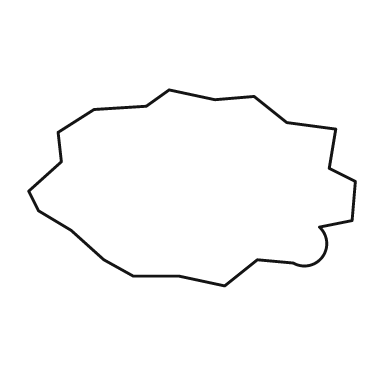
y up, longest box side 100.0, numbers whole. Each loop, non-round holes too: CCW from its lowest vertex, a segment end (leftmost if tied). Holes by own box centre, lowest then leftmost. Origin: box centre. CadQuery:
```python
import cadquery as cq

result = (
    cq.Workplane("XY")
    .moveTo(10.0, -30.0)
    .lineTo(20.0, -22.0)
    .lineTo(31.0, -23.0)
    .threePointArc((40.0, -21.0), (39.0, -12.0))
    .lineTo(49.0, -10.0)
    .lineTo(50.0, 2.0)
    .lineTo(42.0, 6.0)
    .lineTo(44.0, 18.0)
    .lineTo(29.0, 20.0)
    .lineTo(19.0, 28.0)
    .lineTo(7.0, 27.0)
    .lineTo(-7.0, 30.0)
    .lineTo(-14.0, 25.0)
    .lineTo(-30.0, 24.0)
    .lineTo(-41.0, 17.0)
    .lineTo(-40.0, 8.0)
    .lineTo(-50.0, -1.0)
    .lineTo(-47.0, -7.0)
    .lineTo(-37.0, -13.0)
    .lineTo(-27.0, -22.0)
    .lineTo(-18.0, -27.0)
    .lineTo(-4.0, -27.0)
    .close()
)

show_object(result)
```